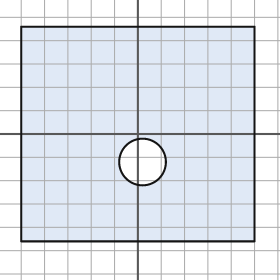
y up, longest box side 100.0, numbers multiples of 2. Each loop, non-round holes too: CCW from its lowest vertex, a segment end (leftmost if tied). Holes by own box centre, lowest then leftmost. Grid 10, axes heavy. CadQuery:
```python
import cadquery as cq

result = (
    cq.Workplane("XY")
    .moveTo(-50.0, -46.0)
    .lineTo(50.0, -46.0)
    .lineTo(50.0, 46.0)
    .lineTo(-50.0, 46.0)
    .close()
    .moveTo(2.0, -12.0)
    .circle(10.0)
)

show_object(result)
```